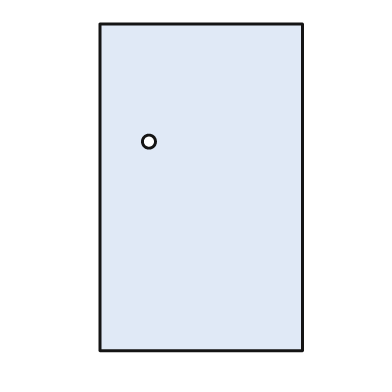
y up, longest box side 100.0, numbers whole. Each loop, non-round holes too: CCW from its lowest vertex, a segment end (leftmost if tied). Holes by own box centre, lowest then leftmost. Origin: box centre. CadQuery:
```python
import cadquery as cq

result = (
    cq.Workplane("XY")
    .moveTo(-31.0, -50.0)
    .lineTo(31.0, -50.0)
    .lineTo(31.0, 50.0)
    .lineTo(-31.0, 50.0)
    .close()
    .moveTo(-16.0, 14.0)
    .circle(2.0)
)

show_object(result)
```